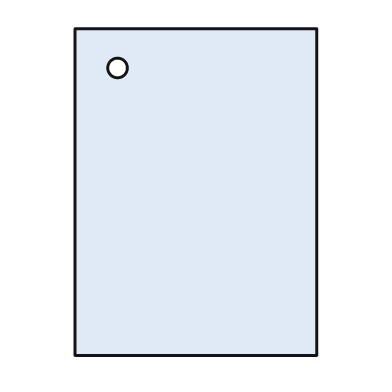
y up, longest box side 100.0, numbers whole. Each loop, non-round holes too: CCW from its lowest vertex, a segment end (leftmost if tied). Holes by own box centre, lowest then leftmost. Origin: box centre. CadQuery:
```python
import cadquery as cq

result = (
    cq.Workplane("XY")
    .moveTo(-37.0, -50.0)
    .lineTo(37.0, -50.0)
    .lineTo(37.0, 50.0)
    .lineTo(-37.0, 50.0)
    .close()
    .moveTo(-24.0, 38.0)
    .circle(3.0)
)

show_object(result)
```